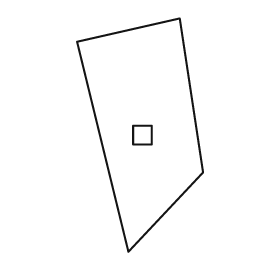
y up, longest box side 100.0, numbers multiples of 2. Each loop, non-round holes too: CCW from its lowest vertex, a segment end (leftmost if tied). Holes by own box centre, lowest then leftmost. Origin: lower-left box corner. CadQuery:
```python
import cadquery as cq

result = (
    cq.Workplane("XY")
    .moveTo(22.0, 0.0)
    .lineTo(54.0, 34.0)
    .lineTo(44.0, 100.0)
    .lineTo(0.0, 90.0)
    .close()
    .moveTo(24.0, 46.0)
    .lineTo(32.0, 46.0)
    .lineTo(32.0, 54.0)
    .lineTo(24.0, 54.0)
    .close()
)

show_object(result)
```